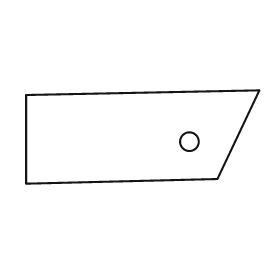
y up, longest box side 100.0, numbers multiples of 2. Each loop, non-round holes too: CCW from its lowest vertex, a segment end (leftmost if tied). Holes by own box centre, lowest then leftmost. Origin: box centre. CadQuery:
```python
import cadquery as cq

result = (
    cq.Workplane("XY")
    .moveTo(-50.0, -20.0)
    .lineTo(32.0, -18.0)
    .lineTo(50.0, 20.0)
    .lineTo(-50.0, 18.0)
    .close()
    .moveTo(20.0, -2.0)
    .circle(4.0)
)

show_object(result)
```